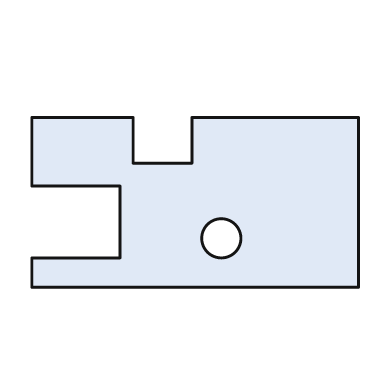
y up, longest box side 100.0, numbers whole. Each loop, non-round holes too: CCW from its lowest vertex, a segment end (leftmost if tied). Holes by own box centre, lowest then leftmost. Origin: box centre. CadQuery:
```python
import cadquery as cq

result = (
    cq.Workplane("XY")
    .moveTo(-50.0, -26.0)
    .lineTo(50.0, -26.0)
    .lineTo(50.0, 26.0)
    .lineTo(-1.0, 26.0)
    .lineTo(-1.0, 12.0)
    .lineTo(-19.0, 12.0)
    .lineTo(-19.0, 26.0)
    .lineTo(-50.0, 26.0)
    .lineTo(-50.0, 5.0)
    .lineTo(-23.0, 5.0)
    .lineTo(-23.0, -17.0)
    .lineTo(-50.0, -17.0)
    .close()
    .moveTo(8.0, -11.0)
    .circle(6.0)
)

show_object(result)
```